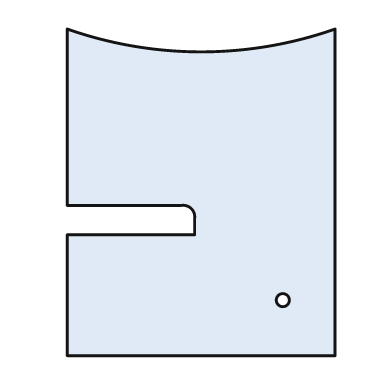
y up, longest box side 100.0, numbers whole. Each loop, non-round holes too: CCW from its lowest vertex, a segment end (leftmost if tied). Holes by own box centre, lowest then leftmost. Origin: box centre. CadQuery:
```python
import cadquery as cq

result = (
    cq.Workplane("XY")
    .moveTo(-41.0, -50.0)
    .lineTo(41.0, -50.0)
    .lineTo(41.0, 50.0)
    .threePointArc((0.0, 43.0), (-41.0, 50.0))
    .lineTo(-41.0, -4.0)
    .lineTo(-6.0, -4.0)
    .threePointArc((-3.0, -5.0), (-2.0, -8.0))
    .lineTo(-2.0, -13.0)
    .lineTo(-41.0, -13.0)
    .close()
    .moveTo(25.0, -33.0)
    .circle(2.0)
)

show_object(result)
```